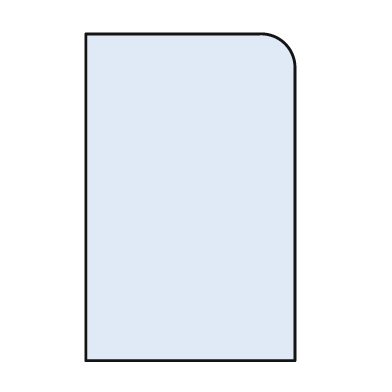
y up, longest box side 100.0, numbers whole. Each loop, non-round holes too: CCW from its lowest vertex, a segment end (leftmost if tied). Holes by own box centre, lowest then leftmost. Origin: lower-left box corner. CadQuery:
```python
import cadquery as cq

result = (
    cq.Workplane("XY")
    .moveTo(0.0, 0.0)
    .lineTo(64.0, 0.0)
    .lineTo(64.0, 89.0)
    .threePointArc((61.0, 97.0), (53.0, 100.0))
    .lineTo(0.0, 100.0)
    .close()
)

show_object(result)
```